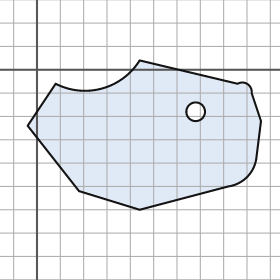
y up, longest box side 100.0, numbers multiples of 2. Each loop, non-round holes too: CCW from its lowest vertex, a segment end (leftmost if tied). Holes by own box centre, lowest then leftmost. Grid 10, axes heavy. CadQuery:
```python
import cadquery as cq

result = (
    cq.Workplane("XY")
    .moveTo(44.0, -60.0)
    .lineTo(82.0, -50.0)
    .threePointArc((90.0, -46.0), (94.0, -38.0))
    .lineTo(96.0, -22.0)
    .lineTo(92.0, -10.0)
    .threePointArc((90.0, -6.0), (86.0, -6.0))
    .lineTo(44.0, 4.0)
    .threePointArc((28.0, -8.0), (8.0, -6.0))
    .lineTo(-4.0, -24.0)
    .lineTo(18.0, -52.0)
    .close()
    .moveTo(68.0, -18.0)
    .circle(4.0)
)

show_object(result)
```